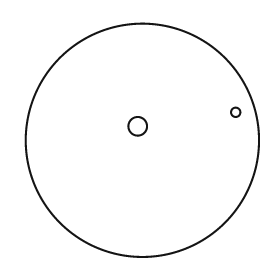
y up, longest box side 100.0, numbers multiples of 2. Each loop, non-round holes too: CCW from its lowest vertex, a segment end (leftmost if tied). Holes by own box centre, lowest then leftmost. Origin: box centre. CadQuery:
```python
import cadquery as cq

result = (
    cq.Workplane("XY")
    .moveTo(0.0, 0.0)
    .circle(50.0)
    .moveTo(-2.0, 6.0)
    .circle(4.0)
    .moveTo(40.0, 12.0)
    .circle(2.0)
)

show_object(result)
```